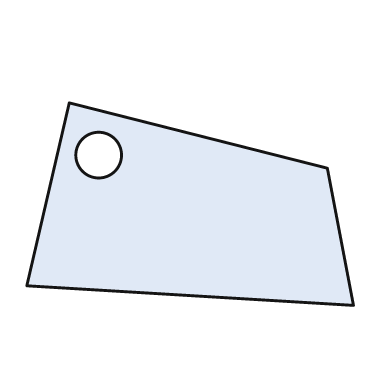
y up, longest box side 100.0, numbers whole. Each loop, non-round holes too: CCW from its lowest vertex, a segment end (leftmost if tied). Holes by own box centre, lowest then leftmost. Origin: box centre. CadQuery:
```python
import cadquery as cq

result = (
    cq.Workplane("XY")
    .moveTo(50.0, -31.0)
    .lineTo(42.0, 11.0)
    .lineTo(-37.0, 31.0)
    .lineTo(-50.0, -25.0)
    .close()
    .moveTo(-28.0, 15.0)
    .circle(7.0)
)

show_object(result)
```